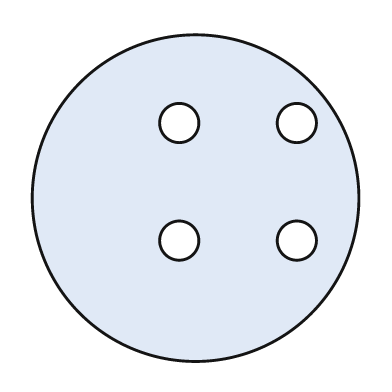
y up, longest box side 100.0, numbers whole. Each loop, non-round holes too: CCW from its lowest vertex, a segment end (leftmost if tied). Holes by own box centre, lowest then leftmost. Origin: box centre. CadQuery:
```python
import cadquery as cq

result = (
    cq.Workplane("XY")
    .moveTo(0.0, 0.0)
    .circle(50.0)
    .moveTo(-5.0, -13.0)
    .circle(6.0)
    .moveTo(31.0, -13.0)
    .circle(6.0)
    .moveTo(-5.0, 23.0)
    .circle(6.0)
    .moveTo(31.0, 23.0)
    .circle(6.0)
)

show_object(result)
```